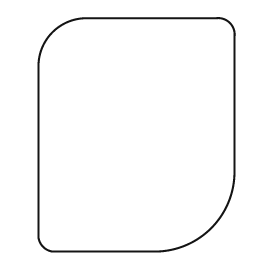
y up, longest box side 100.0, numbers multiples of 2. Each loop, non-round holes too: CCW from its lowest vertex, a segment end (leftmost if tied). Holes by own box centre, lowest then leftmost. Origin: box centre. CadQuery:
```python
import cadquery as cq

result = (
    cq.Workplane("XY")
    .moveTo(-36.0, -50.0)
    .lineTo(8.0, -50.0)
    .threePointArc((32.0, -40.0), (42.0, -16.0))
    .lineTo(42.0, 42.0)
    .threePointArc((40.0, 48.0), (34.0, 50.0))
    .lineTo(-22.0, 50.0)
    .threePointArc((-36.0, 44.0), (-42.0, 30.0))
    .lineTo(-42.0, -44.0)
    .threePointArc((-40.0, -48.0), (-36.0, -50.0))
    .close()
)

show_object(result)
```